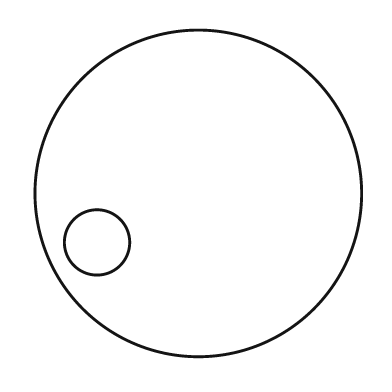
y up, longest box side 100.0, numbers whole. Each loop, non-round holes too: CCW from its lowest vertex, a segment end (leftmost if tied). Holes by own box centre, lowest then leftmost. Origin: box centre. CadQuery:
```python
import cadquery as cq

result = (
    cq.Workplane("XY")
    .moveTo(0.0, 0.0)
    .circle(50.0)
    .moveTo(-31.0, -15.0)
    .circle(10.0)
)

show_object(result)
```